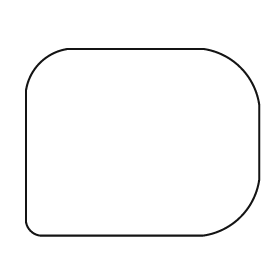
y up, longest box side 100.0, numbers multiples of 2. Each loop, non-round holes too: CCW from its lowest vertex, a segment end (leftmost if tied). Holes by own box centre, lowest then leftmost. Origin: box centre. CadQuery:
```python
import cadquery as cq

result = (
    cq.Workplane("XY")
    .moveTo(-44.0, -40.0)
    .lineTo(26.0, -40.0)
    .threePointArc((42.0, -32.0), (50.0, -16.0))
    .lineTo(50.0, 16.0)
    .threePointArc((42.0, 32.0), (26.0, 40.0))
    .lineTo(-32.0, 40.0)
    .threePointArc((-44.0, 34.0), (-50.0, 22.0))
    .lineTo(-50.0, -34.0)
    .threePointArc((-48.0, -38.0), (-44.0, -40.0))
    .close()
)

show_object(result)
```